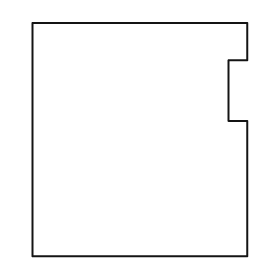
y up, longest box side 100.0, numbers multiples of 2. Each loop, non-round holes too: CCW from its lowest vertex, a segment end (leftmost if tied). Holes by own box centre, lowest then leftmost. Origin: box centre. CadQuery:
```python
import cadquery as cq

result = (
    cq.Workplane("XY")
    .moveTo(-46.0, -50.0)
    .lineTo(46.0, -50.0)
    .lineTo(46.0, 8.0)
    .lineTo(38.0, 8.0)
    .lineTo(38.0, 34.0)
    .lineTo(46.0, 34.0)
    .lineTo(46.0, 50.0)
    .lineTo(-46.0, 50.0)
    .close()
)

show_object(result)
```